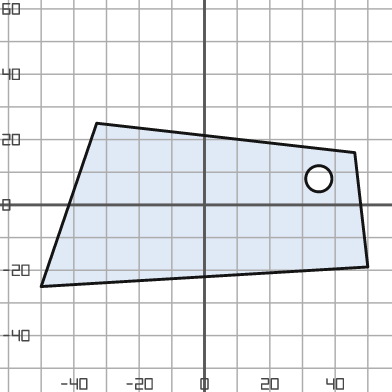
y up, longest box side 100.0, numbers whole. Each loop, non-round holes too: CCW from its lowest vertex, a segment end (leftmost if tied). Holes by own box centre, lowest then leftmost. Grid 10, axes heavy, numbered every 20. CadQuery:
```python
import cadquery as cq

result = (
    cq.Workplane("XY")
    .moveTo(-50.0, -25.0)
    .lineTo(50.0, -19.0)
    .lineTo(46.0, 16.0)
    .lineTo(-33.0, 25.0)
    .close()
    .moveTo(35.0, 8.0)
    .circle(4.0)
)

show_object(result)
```